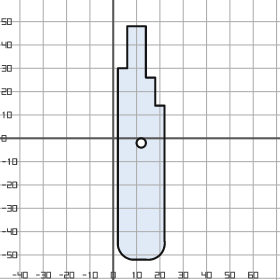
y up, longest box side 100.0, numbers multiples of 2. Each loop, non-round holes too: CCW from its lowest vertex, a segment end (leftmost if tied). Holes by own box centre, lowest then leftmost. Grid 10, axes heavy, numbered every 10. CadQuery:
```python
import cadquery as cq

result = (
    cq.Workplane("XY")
    .moveTo(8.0, -52.0)
    .lineTo(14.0, -52.0)
    .threePointArc((20.0, -50.0), (22.0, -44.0))
    .lineTo(22.0, 14.0)
    .lineTo(18.0, 14.0)
    .lineTo(18.0, 26.0)
    .lineTo(14.0, 26.0)
    .lineTo(14.0, 48.0)
    .lineTo(6.0, 48.0)
    .lineTo(6.0, 30.0)
    .lineTo(2.0, 30.0)
    .lineTo(2.0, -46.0)
    .threePointArc((4.0, -50.0), (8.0, -52.0))
    .close()
    .moveTo(12.0, -2.0)
    .circle(2.0)
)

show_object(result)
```